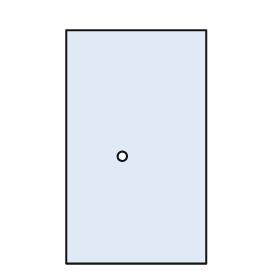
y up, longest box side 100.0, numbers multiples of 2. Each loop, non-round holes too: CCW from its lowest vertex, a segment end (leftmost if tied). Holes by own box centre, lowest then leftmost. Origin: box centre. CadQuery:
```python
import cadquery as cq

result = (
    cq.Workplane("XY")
    .moveTo(-30.0, -50.0)
    .lineTo(30.0, -50.0)
    .lineTo(30.0, 50.0)
    .lineTo(-30.0, 50.0)
    .close()
    .moveTo(-6.0, -4.0)
    .circle(2.0)
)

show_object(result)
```